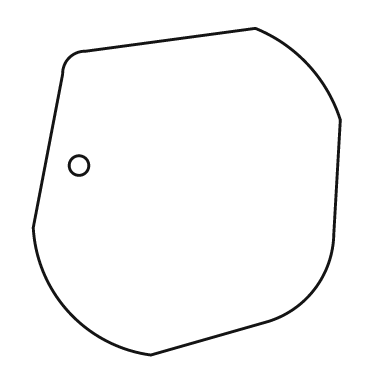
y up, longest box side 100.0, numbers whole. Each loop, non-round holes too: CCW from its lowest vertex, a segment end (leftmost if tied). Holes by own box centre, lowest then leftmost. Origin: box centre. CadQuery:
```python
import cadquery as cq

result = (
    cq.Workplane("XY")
    .moveTo(-11.0, -50.0)
    .lineTo(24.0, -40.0)
    .threePointArc((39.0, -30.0), (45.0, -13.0))
    .lineTo(47.0, 22.0)
    .threePointArc((37.0, 39.0), (21.0, 50.0))
    .lineTo(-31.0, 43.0)
    .threePointArc((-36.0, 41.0), (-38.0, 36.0))
    .lineTo(-47.0, -11.0)
    .threePointArc((-36.0, -37.0), (-11.0, -50.0))
    .close()
    .moveTo(-33.0, 8.0)
    .circle(3.0)
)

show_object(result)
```